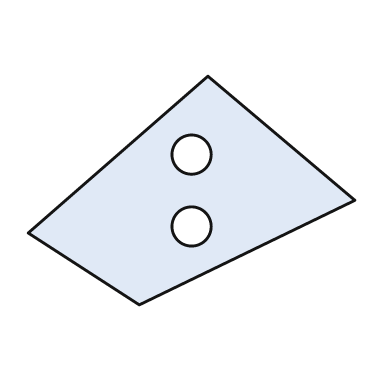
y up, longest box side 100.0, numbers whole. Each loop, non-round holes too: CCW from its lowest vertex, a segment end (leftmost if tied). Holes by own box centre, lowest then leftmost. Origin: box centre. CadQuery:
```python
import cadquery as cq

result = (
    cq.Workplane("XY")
    .moveTo(-16.0, -35.0)
    .lineTo(50.0, -3.0)
    .lineTo(5.0, 35.0)
    .lineTo(-50.0, -13.0)
    .close()
    .moveTo(0.0, -11.0)
    .circle(6.0)
    .moveTo(0.0, 11.0)
    .circle(6.0)
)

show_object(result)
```